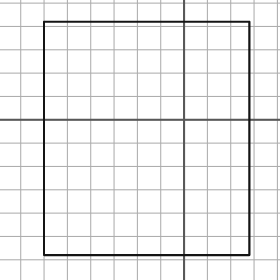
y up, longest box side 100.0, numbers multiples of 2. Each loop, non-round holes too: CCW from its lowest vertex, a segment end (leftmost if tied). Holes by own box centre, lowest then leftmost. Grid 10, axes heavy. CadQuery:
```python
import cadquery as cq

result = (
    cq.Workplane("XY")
    .moveTo(-60.0, -58.0)
    .lineTo(28.0, -58.0)
    .lineTo(28.0, 42.0)
    .lineTo(-60.0, 42.0)
    .close()
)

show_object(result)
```